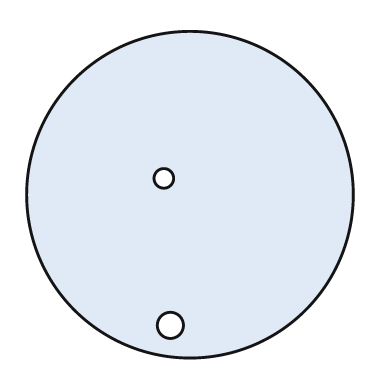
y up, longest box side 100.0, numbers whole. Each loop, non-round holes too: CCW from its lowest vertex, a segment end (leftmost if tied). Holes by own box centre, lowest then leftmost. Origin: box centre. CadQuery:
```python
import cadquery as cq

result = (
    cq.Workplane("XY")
    .moveTo(0.0, 0.0)
    .circle(50.0)
    .moveTo(-6.0, -40.0)
    .circle(4.0)
    .moveTo(-8.0, 5.0)
    .circle(3.0)
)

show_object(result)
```